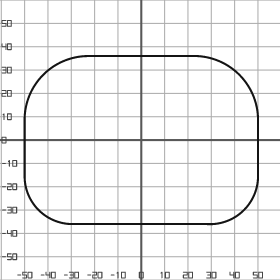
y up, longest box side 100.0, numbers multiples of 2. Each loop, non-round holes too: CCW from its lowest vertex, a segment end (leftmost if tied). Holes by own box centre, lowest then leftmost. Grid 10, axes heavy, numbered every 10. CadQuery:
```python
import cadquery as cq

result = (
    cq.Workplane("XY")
    .moveTo(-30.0, -36.0)
    .lineTo(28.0, -36.0)
    .threePointArc((44.0, -30.0), (50.0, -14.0))
    .lineTo(50.0, 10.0)
    .threePointArc((42.0, 28.0), (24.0, 36.0))
    .lineTo(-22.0, 36.0)
    .threePointArc((-42.0, 28.0), (-50.0, 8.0))
    .lineTo(-50.0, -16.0)
    .threePointArc((-44.0, -30.0), (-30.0, -36.0))
    .close()
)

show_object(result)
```